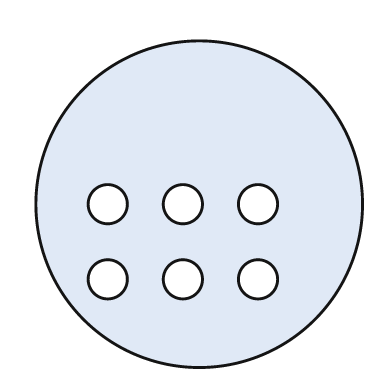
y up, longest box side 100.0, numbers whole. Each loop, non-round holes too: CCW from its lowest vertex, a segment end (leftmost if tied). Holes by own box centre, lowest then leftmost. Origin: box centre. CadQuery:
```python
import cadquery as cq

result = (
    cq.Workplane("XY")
    .moveTo(0.0, 0.0)
    .circle(50.0)
    .moveTo(-28.0, -23.0)
    .circle(6.0)
    .moveTo(-5.0, -23.0)
    .circle(6.0)
    .moveTo(18.0, -23.0)
    .circle(6.0)
    .moveTo(-28.0, 0.0)
    .circle(6.0)
    .moveTo(-5.0, 0.0)
    .circle(6.0)
    .moveTo(18.0, 0.0)
    .circle(6.0)
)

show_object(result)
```